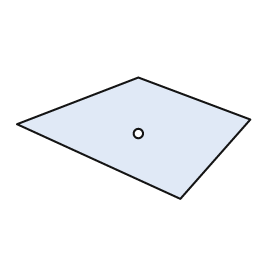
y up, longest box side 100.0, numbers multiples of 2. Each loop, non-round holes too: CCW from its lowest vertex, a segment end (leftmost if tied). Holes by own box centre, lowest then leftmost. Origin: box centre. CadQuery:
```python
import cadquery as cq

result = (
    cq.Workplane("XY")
    .moveTo(20.0, -26.0)
    .lineTo(50.0, 8.0)
    .lineTo(2.0, 26.0)
    .lineTo(-50.0, 6.0)
    .close()
    .moveTo(2.0, 2.0)
    .circle(2.0)
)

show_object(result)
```